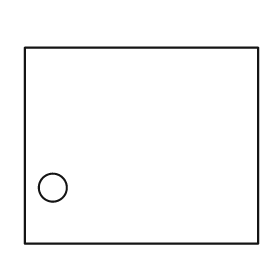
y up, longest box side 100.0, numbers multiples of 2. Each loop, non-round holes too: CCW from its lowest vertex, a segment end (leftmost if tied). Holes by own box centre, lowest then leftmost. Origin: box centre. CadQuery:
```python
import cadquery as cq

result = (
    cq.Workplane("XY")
    .moveTo(-50.0, -42.0)
    .lineTo(50.0, -42.0)
    .lineTo(50.0, 42.0)
    .lineTo(-50.0, 42.0)
    .close()
    .moveTo(-38.0, -18.0)
    .circle(6.0)
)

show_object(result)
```